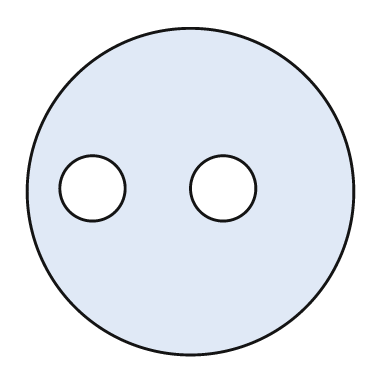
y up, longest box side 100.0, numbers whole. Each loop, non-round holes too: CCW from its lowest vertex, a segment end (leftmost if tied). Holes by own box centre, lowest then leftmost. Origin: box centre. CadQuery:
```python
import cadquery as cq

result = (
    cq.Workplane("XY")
    .moveTo(0.0, 0.0)
    .circle(50.0)
    .moveTo(-30.0, 1.0)
    .circle(10.0)
    .moveTo(10.0, 1.0)
    .circle(10.0)
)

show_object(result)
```